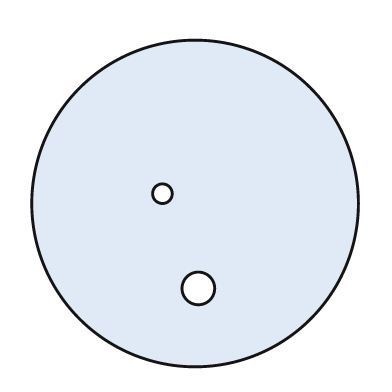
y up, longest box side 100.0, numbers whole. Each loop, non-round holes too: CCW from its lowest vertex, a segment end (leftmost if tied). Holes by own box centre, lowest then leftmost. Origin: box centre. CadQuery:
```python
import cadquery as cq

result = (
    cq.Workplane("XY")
    .moveTo(0.0, 0.0)
    .circle(50.0)
    .moveTo(1.0, -26.0)
    .circle(5.0)
    .moveTo(-10.0, 3.0)
    .circle(3.0)
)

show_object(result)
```